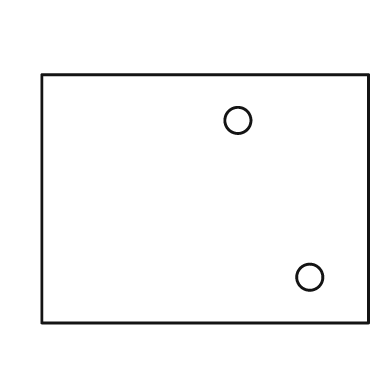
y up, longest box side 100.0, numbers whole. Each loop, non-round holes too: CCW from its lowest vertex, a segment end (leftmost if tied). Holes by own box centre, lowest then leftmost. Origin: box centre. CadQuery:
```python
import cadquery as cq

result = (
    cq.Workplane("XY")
    .moveTo(-50.0, -38.0)
    .lineTo(50.0, -38.0)
    .lineTo(50.0, 38.0)
    .lineTo(-50.0, 38.0)
    .close()
    .moveTo(32.0, -24.0)
    .circle(4.0)
    .moveTo(10.0, 24.0)
    .circle(4.0)
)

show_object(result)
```